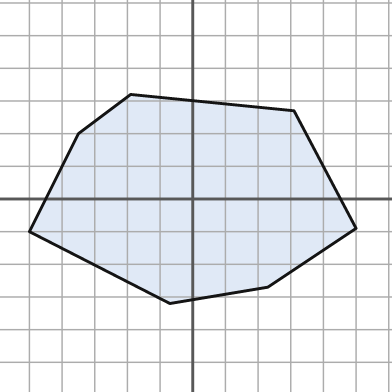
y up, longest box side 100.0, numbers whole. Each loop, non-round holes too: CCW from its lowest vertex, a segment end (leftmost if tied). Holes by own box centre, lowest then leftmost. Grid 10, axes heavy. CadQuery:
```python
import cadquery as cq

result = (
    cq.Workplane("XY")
    .moveTo(-7.0, -32.0)
    .lineTo(23.0, -27.0)
    .lineTo(50.0, -9.0)
    .lineTo(31.0, 27.0)
    .lineTo(-19.0, 32.0)
    .lineTo(-35.0, 20.0)
    .lineTo(-50.0, -10.0)
    .close()
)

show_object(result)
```